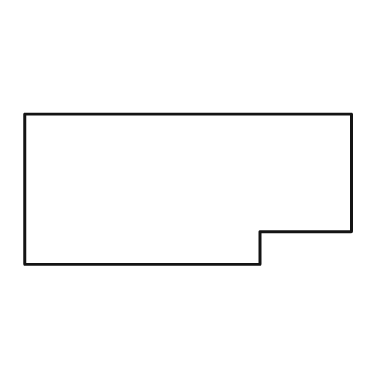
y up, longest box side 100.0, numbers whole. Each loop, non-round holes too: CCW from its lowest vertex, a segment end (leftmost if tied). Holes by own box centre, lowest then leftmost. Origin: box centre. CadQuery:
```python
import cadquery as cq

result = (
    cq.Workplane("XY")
    .moveTo(-50.0, -23.0)
    .lineTo(22.0, -23.0)
    .lineTo(22.0, -13.0)
    .lineTo(50.0, -13.0)
    .lineTo(50.0, 23.0)
    .lineTo(-50.0, 23.0)
    .close()
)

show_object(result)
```